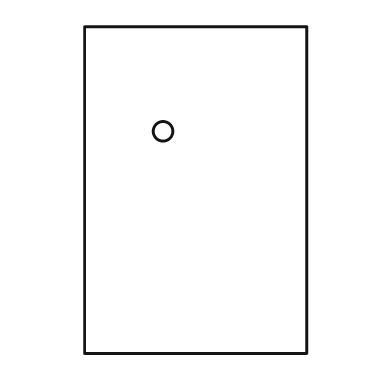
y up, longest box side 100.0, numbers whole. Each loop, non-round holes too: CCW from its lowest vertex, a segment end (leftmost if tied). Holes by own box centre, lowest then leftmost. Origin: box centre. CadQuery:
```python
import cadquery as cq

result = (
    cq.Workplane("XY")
    .moveTo(-34.0, -50.0)
    .lineTo(34.0, -50.0)
    .lineTo(34.0, 50.0)
    .lineTo(-34.0, 50.0)
    .close()
    .moveTo(-10.0, 18.0)
    .circle(3.0)
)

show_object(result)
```